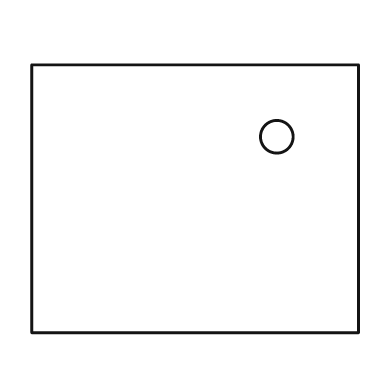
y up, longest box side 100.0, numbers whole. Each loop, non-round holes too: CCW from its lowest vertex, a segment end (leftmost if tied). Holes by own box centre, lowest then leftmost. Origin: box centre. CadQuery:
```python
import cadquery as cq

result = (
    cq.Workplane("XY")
    .moveTo(-50.0, -41.0)
    .lineTo(50.0, -41.0)
    .lineTo(50.0, 41.0)
    .lineTo(-50.0, 41.0)
    .close()
    .moveTo(25.0, 19.0)
    .circle(5.0)
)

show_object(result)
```